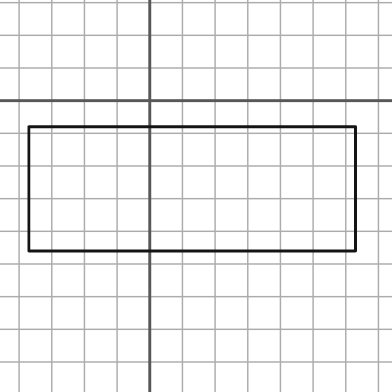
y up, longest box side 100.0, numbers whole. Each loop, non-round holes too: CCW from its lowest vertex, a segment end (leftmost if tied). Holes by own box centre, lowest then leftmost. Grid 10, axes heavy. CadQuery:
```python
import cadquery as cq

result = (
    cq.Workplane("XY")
    .moveTo(-37.0, -46.0)
    .lineTo(63.0, -46.0)
    .lineTo(63.0, -8.0)
    .lineTo(-37.0, -8.0)
    .close()
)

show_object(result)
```